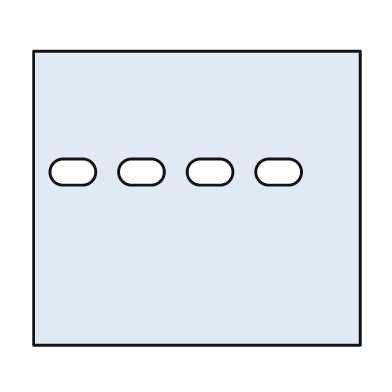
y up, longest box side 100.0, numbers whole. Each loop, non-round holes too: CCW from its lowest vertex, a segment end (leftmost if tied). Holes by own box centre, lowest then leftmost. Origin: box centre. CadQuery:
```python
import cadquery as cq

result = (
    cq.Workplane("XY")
    .moveTo(-50.0, -45.0)
    .lineTo(50.0, -45.0)
    .lineTo(50.0, 45.0)
    .lineTo(-50.0, 45.0)
    .close()
    .moveTo(-41.0, 4.0)
    .lineTo(-35.0, 4.0)
    .threePointArc((-31.0, 8.0), (-35.0, 12.0))
    .lineTo(-41.0, 12.0)
    .threePointArc((-45.0, 8.0), (-41.0, 4.0))
    .close()
    .moveTo(-20.0, 4.0)
    .lineTo(-14.0, 4.0)
    .threePointArc((-10.0, 8.0), (-14.0, 12.0))
    .lineTo(-20.0, 12.0)
    .threePointArc((-24.0, 8.0), (-20.0, 4.0))
    .close()
    .moveTo(1.0, 4.0)
    .lineTo(7.0, 4.0)
    .threePointArc((11.0, 8.0), (7.0, 12.0))
    .lineTo(1.0, 12.0)
    .threePointArc((-3.0, 8.0), (1.0, 4.0))
    .close()
    .moveTo(22.0, 4.0)
    .lineTo(28.0, 4.0)
    .threePointArc((32.0, 8.0), (28.0, 12.0))
    .lineTo(22.0, 12.0)
    .threePointArc((18.0, 8.0), (22.0, 4.0))
    .close()
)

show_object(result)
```